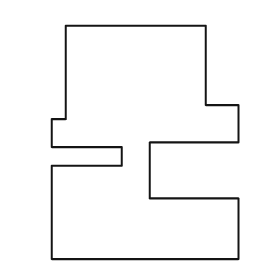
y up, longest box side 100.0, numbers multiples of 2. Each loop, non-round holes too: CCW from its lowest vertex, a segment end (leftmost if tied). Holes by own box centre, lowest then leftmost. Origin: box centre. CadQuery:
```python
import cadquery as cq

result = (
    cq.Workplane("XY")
    .moveTo(-40.0, -50.0)
    .lineTo(40.0, -50.0)
    .lineTo(40.0, -24.0)
    .lineTo(2.0, -24.0)
    .lineTo(2.0, 0.0)
    .lineTo(40.0, 0.0)
    .lineTo(40.0, 16.0)
    .lineTo(26.0, 16.0)
    .lineTo(26.0, 50.0)
    .lineTo(-34.0, 50.0)
    .lineTo(-34.0, 10.0)
    .lineTo(-40.0, 10.0)
    .lineTo(-40.0, -2.0)
    .lineTo(-10.0, -2.0)
    .lineTo(-10.0, -10.0)
    .lineTo(-40.0, -10.0)
    .close()
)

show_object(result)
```